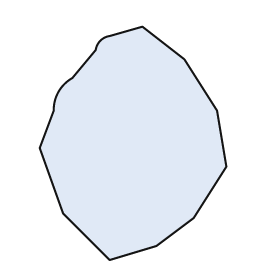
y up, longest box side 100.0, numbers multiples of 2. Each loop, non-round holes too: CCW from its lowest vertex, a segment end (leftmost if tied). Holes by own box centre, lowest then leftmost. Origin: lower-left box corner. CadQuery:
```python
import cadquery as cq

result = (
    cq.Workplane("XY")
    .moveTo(30.0, 0.0)
    .lineTo(50.0, 6.0)
    .lineTo(66.0, 18.0)
    .lineTo(80.0, 40.0)
    .lineTo(76.0, 64.0)
    .lineTo(62.0, 86.0)
    .lineTo(44.0, 100.0)
    .lineTo(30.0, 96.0)
    .threePointArc((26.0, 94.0), (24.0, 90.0))
    .lineTo(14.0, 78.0)
    .threePointArc((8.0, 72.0), (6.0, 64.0))
    .lineTo(0.0, 48.0)
    .lineTo(10.0, 20.0)
    .close()
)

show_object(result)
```